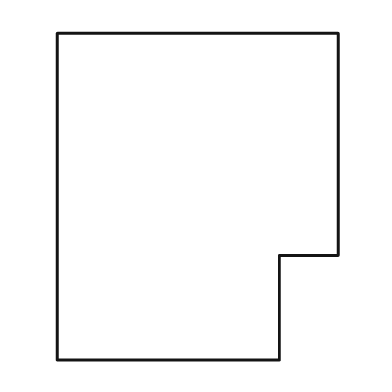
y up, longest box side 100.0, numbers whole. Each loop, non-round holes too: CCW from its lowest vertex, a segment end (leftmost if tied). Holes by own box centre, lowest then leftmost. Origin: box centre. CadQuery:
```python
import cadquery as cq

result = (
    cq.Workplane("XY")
    .moveTo(-43.0, -50.0)
    .lineTo(25.0, -50.0)
    .lineTo(25.0, -18.0)
    .lineTo(43.0, -18.0)
    .lineTo(43.0, 50.0)
    .lineTo(-43.0, 50.0)
    .close()
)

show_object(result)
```